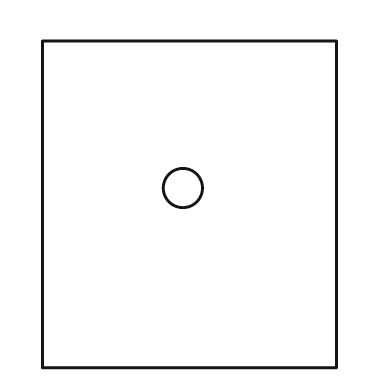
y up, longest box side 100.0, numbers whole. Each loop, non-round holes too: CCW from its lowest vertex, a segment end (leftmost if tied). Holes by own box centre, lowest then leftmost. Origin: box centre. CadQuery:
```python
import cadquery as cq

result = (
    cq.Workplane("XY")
    .moveTo(-45.0, -50.0)
    .lineTo(45.0, -50.0)
    .lineTo(45.0, 50.0)
    .lineTo(-45.0, 50.0)
    .close()
    .moveTo(-2.0, 5.0)
    .circle(6.0)
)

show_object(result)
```